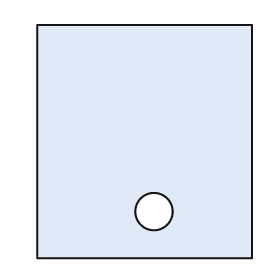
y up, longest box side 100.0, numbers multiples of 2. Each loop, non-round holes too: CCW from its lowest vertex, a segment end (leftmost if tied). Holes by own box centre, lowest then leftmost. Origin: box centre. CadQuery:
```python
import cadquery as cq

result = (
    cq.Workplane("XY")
    .moveTo(-46.0, -50.0)
    .lineTo(46.0, -50.0)
    .lineTo(46.0, 50.0)
    .lineTo(-46.0, 50.0)
    .close()
    .moveTo(4.0, -30.0)
    .circle(8.0)
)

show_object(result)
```